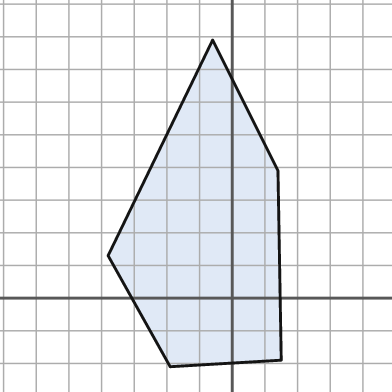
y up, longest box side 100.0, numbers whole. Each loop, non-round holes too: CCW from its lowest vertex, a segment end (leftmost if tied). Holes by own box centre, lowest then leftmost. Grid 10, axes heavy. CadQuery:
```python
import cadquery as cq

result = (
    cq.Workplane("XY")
    .moveTo(-19.0, -21.0)
    .lineTo(15.0, -19.0)
    .lineTo(14.0, 39.0)
    .lineTo(-6.0, 79.0)
    .lineTo(-38.0, 13.0)
    .close()
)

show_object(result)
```